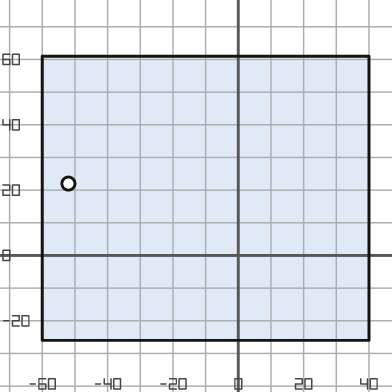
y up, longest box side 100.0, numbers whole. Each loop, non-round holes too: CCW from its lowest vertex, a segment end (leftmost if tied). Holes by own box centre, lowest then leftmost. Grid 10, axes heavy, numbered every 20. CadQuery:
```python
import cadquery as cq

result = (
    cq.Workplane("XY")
    .moveTo(-60.0, -26.0)
    .lineTo(40.0, -26.0)
    .lineTo(40.0, 61.0)
    .lineTo(-60.0, 61.0)
    .close()
    .moveTo(-52.0, 22.0)
    .circle(2.0)
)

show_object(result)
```